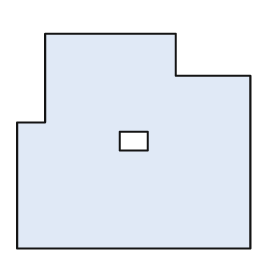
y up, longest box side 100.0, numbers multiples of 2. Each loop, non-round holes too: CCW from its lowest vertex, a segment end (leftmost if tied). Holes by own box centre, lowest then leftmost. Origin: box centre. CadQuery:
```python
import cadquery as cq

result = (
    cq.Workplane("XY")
    .moveTo(-50.0, -46.0)
    .lineTo(50.0, -46.0)
    .lineTo(50.0, 28.0)
    .lineTo(18.0, 28.0)
    .lineTo(18.0, 46.0)
    .lineTo(-38.0, 46.0)
    .lineTo(-38.0, 8.0)
    .lineTo(-50.0, 8.0)
    .close()
    .moveTo(-6.0, -4.0)
    .lineTo(6.0, -4.0)
    .lineTo(6.0, 4.0)
    .lineTo(-6.0, 4.0)
    .close()
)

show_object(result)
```